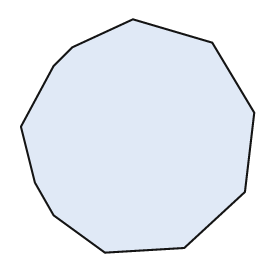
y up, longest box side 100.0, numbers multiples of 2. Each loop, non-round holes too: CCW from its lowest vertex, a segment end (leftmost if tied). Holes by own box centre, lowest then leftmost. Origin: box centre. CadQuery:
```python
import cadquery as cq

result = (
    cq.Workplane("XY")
    .moveTo(-14.0, -50.0)
    .lineTo(20.0, -48.0)
    .lineTo(46.0, -24.0)
    .lineTo(50.0, 10.0)
    .lineTo(32.0, 40.0)
    .lineTo(-2.0, 50.0)
    .lineTo(-28.0, 38.0)
    .lineTo(-36.0, 30.0)
    .lineTo(-50.0, 4.0)
    .lineTo(-44.0, -20.0)
    .lineTo(-36.0, -34.0)
    .close()
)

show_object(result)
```